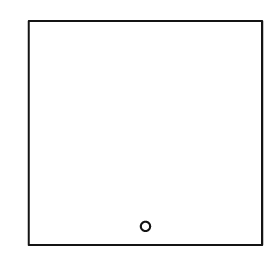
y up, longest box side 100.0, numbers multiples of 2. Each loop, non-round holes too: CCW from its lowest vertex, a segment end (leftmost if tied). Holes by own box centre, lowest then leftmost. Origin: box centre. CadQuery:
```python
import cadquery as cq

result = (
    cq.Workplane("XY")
    .moveTo(-50.0, -48.0)
    .lineTo(50.0, -48.0)
    .lineTo(50.0, 48.0)
    .lineTo(-50.0, 48.0)
    .close()
    .moveTo(0.0, -40.0)
    .circle(2.0)
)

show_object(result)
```